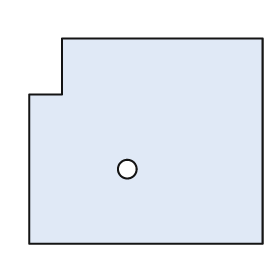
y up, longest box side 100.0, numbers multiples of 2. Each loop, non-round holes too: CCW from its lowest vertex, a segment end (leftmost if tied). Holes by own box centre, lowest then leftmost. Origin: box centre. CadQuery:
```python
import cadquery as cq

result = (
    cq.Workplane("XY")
    .moveTo(-50.0, -44.0)
    .lineTo(50.0, -44.0)
    .lineTo(50.0, 44.0)
    .lineTo(-36.0, 44.0)
    .lineTo(-36.0, 20.0)
    .lineTo(-50.0, 20.0)
    .close()
    .moveTo(-8.0, -12.0)
    .circle(4.0)
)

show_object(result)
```